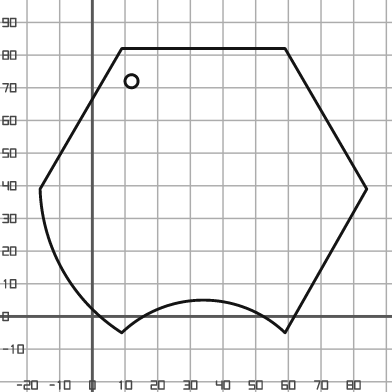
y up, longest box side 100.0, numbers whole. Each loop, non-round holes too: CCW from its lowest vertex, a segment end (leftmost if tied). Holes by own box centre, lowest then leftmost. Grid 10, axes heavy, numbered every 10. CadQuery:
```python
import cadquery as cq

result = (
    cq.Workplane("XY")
    .moveTo(9.0, -5.0)
    .threePointArc((34.0, 5.0), (59.0, -5.0))
    .lineTo(84.0, 39.0)
    .lineTo(59.0, 82.0)
    .lineTo(9.0, 82.0)
    .lineTo(-16.0, 39.0)
    .threePointArc((-9.0, 14.0), (9.0, -5.0))
    .close()
    .moveTo(12.0, 72.0)
    .circle(2.0)
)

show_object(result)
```